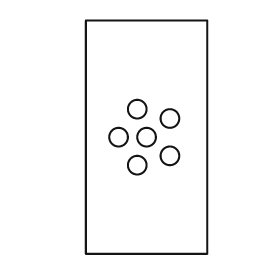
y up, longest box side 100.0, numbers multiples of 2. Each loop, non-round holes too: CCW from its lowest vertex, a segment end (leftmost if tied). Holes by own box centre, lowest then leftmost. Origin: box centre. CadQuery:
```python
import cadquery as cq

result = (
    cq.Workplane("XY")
    .moveTo(-26.0, -50.0)
    .lineTo(26.0, -50.0)
    .lineTo(26.0, 50.0)
    .lineTo(-26.0, 50.0)
    .close()
    .moveTo(-4.0, -12.0)
    .circle(4.0)
    .moveTo(10.0, -8.0)
    .circle(4.0)
    .moveTo(-12.0, 0.0)
    .circle(4.0)
    .moveTo(0.0, 0.0)
    .circle(4.0)
    .moveTo(10.0, 8.0)
    .circle(4.0)
    .moveTo(-4.0, 12.0)
    .circle(4.0)
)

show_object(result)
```